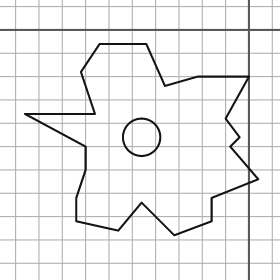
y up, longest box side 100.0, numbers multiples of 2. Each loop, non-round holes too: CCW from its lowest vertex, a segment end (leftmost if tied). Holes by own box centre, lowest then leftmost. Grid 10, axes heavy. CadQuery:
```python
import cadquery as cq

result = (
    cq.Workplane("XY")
    .moveTo(-32.0, -88.0)
    .lineTo(-16.0, -82.0)
    .lineTo(-16.0, -72.0)
    .lineTo(4.0, -64.0)
    .lineTo(-8.0, -50.0)
    .lineTo(-4.0, -46.0)
    .lineTo(-10.0, -38.0)
    .lineTo(0.0, -20.0)
    .lineTo(-22.0, -20.0)
    .lineTo(-36.0, -24.0)
    .lineTo(-44.0, -6.0)
    .lineTo(-64.0, -6.0)
    .lineTo(-72.0, -18.0)
    .lineTo(-66.0, -36.0)
    .lineTo(-96.0, -36.0)
    .lineTo(-70.0, -50.0)
    .lineTo(-70.0, -60.0)
    .lineTo(-74.0, -72.0)
    .lineTo(-74.0, -82.0)
    .lineTo(-56.0, -86.0)
    .lineTo(-46.0, -74.0)
    .close()
    .moveTo(-46.0, -46.0)
    .circle(8.0)
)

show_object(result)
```